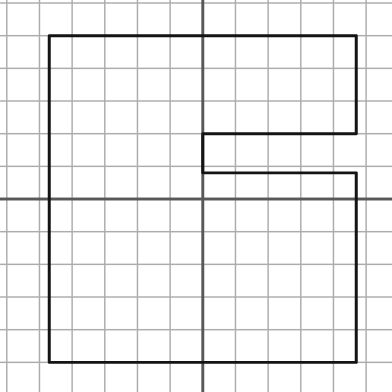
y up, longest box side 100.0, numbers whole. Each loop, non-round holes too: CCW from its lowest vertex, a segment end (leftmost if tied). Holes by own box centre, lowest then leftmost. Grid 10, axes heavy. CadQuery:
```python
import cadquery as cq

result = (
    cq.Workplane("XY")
    .moveTo(-47.0, -50.0)
    .lineTo(47.0, -50.0)
    .lineTo(47.0, 8.0)
    .lineTo(0.0, 8.0)
    .lineTo(0.0, 20.0)
    .lineTo(47.0, 20.0)
    .lineTo(47.0, 50.0)
    .lineTo(-47.0, 50.0)
    .close()
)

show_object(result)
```